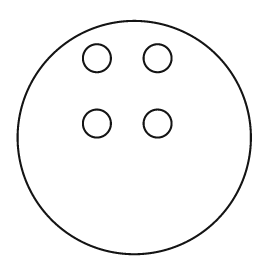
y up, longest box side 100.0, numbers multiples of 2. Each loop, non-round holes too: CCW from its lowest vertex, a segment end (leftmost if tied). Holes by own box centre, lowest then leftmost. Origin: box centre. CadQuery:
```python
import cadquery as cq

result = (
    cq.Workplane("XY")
    .moveTo(0.0, 0.0)
    .circle(50.0)
    .moveTo(-16.0, 6.0)
    .circle(6.0)
    .moveTo(10.0, 6.0)
    .circle(6.0)
    .moveTo(-16.0, 34.0)
    .circle(6.0)
    .moveTo(10.0, 34.0)
    .circle(6.0)
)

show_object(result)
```